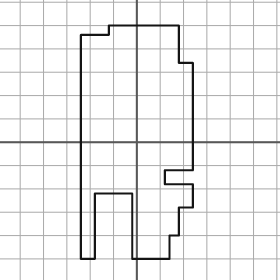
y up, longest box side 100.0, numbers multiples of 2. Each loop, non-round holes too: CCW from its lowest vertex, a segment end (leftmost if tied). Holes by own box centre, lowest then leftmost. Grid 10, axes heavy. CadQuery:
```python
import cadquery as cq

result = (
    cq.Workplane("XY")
    .moveTo(-24.0, -50.0)
    .lineTo(-18.0, -50.0)
    .lineTo(-18.0, -22.0)
    .lineTo(-2.0, -22.0)
    .lineTo(-2.0, -50.0)
    .lineTo(14.0, -50.0)
    .lineTo(14.0, -40.0)
    .lineTo(18.0, -40.0)
    .lineTo(18.0, -28.0)
    .lineTo(24.0, -28.0)
    .lineTo(24.0, -18.0)
    .lineTo(12.0, -18.0)
    .lineTo(12.0, -12.0)
    .lineTo(24.0, -12.0)
    .lineTo(24.0, 34.0)
    .lineTo(18.0, 34.0)
    .lineTo(18.0, 50.0)
    .lineTo(-12.0, 50.0)
    .lineTo(-12.0, 46.0)
    .lineTo(-24.0, 46.0)
    .close()
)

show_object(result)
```